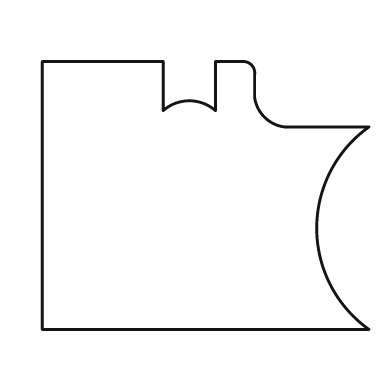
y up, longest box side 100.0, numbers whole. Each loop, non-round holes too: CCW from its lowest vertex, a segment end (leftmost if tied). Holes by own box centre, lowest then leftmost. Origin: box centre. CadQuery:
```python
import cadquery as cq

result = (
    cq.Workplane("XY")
    .moveTo(-50.0, -41.0)
    .lineTo(50.0, -41.0)
    .threePointArc((34.0, -10.0), (50.0, 21.0))
    .lineTo(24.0, 21.0)
    .threePointArc((18.0, 24.0), (15.0, 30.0))
    .lineTo(15.0, 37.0)
    .threePointArc((14.0, 40.0), (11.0, 41.0))
    .lineTo(3.0, 41.0)
    .lineTo(3.0, 26.0)
    .threePointArc((-5.0, 29.0), (-13.0, 26.0))
    .lineTo(-13.0, 41.0)
    .lineTo(-50.0, 41.0)
    .close()
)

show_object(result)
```